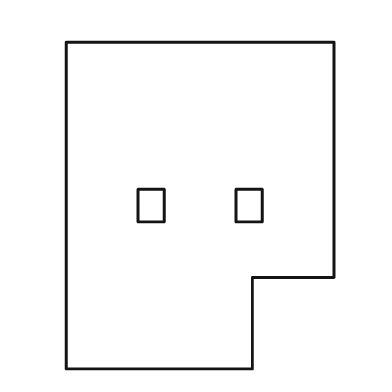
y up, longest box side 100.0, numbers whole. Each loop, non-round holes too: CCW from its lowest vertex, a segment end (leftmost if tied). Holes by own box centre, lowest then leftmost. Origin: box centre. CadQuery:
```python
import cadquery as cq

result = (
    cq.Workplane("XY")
    .moveTo(-41.0, -50.0)
    .lineTo(16.0, -50.0)
    .lineTo(16.0, -22.0)
    .lineTo(41.0, -22.0)
    .lineTo(41.0, 50.0)
    .lineTo(-41.0, 50.0)
    .close()
    .moveTo(-19.0, -5.0)
    .lineTo(-11.0, -5.0)
    .lineTo(-11.0, 5.0)
    .lineTo(-19.0, 5.0)
    .close()
    .moveTo(11.0, -5.0)
    .lineTo(19.0, -5.0)
    .lineTo(19.0, 5.0)
    .lineTo(11.0, 5.0)
    .close()
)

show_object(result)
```